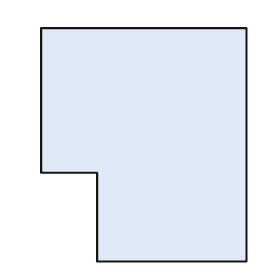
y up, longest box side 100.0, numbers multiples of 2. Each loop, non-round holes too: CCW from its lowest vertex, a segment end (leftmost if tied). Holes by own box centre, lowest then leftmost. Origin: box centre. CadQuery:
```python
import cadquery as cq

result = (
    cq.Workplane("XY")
    .moveTo(-20.0, -50.0)
    .lineTo(44.0, -50.0)
    .lineTo(44.0, 50.0)
    .lineTo(-44.0, 50.0)
    .lineTo(-44.0, -12.0)
    .lineTo(-20.0, -12.0)
    .close()
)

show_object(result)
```